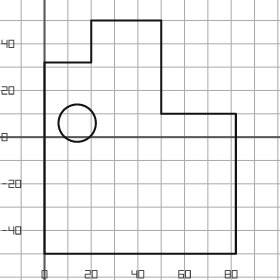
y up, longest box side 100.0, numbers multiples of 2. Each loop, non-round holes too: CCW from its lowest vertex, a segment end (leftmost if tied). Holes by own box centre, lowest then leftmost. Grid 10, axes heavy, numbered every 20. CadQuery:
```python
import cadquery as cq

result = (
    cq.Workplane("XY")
    .moveTo(0.0, -50.0)
    .lineTo(82.0, -50.0)
    .lineTo(82.0, 10.0)
    .lineTo(50.0, 10.0)
    .lineTo(50.0, 50.0)
    .lineTo(20.0, 50.0)
    .lineTo(20.0, 32.0)
    .lineTo(0.0, 32.0)
    .close()
    .moveTo(14.0, 6.0)
    .circle(8.0)
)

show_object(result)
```